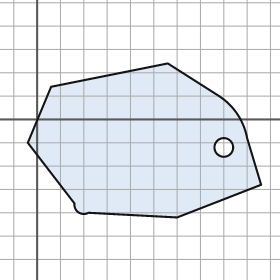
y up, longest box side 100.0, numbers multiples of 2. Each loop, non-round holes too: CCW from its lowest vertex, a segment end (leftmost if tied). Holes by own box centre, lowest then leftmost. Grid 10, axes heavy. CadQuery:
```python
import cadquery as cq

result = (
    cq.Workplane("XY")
    .moveTo(60.0, -42.0)
    .lineTo(96.0, -28.0)
    .lineTo(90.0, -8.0)
    .threePointArc((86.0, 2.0), (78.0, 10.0))
    .lineTo(56.0, 24.0)
    .lineTo(6.0, 14.0)
    .lineTo(-4.0, -10.0)
    .lineTo(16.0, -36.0)
    .threePointArc((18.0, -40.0), (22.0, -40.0))
    .close()
    .moveTo(80.0, -12.0)
    .circle(4.0)
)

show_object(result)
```